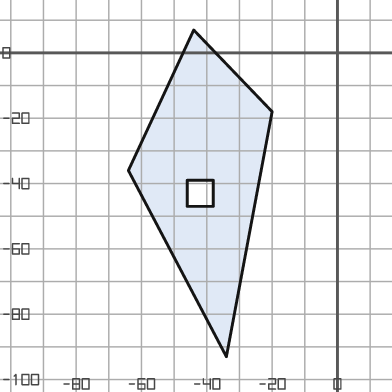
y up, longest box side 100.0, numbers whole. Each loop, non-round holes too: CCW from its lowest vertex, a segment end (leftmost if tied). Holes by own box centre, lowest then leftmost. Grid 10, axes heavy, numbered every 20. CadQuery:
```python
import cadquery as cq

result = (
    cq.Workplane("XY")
    .moveTo(-34.0, -93.0)
    .lineTo(-20.0, -18.0)
    .lineTo(-44.0, 7.0)
    .lineTo(-64.0, -36.0)
    .close()
    .moveTo(-46.0, -47.0)
    .lineTo(-38.0, -47.0)
    .lineTo(-38.0, -39.0)
    .lineTo(-46.0, -39.0)
    .close()
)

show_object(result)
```